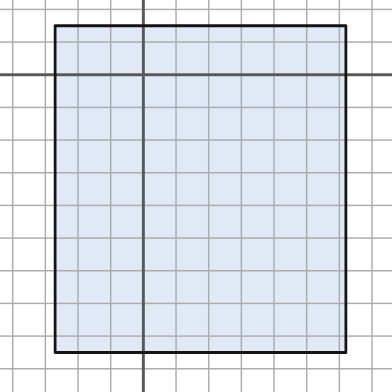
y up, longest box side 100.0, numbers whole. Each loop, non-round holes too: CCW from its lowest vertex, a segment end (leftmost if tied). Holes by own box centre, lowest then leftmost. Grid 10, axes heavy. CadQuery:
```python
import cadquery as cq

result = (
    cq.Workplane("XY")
    .moveTo(-27.0, -85.0)
    .lineTo(62.0, -85.0)
    .lineTo(62.0, 15.0)
    .lineTo(-27.0, 15.0)
    .close()
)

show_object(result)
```